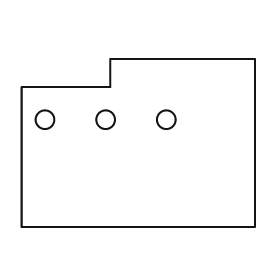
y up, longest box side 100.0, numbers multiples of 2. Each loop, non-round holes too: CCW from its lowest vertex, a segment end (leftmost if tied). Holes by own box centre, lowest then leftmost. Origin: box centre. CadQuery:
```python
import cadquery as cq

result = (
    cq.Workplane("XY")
    .moveTo(-50.0, -36.0)
    .lineTo(50.0, -36.0)
    .lineTo(50.0, 36.0)
    .lineTo(-12.0, 36.0)
    .lineTo(-12.0, 24.0)
    .lineTo(-50.0, 24.0)
    .close()
    .moveTo(-40.0, 10.0)
    .circle(4.0)
    .moveTo(-14.0, 10.0)
    .circle(4.0)
    .moveTo(12.0, 10.0)
    .circle(4.0)
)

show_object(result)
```